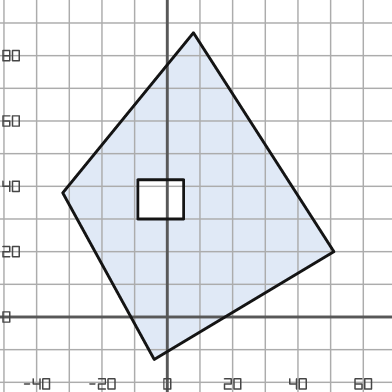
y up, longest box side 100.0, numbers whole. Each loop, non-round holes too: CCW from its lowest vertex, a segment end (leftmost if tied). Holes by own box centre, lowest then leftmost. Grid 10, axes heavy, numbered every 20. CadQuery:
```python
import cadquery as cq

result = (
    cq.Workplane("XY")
    .moveTo(-4.0, -13.0)
    .lineTo(51.0, 20.0)
    .lineTo(8.0, 87.0)
    .lineTo(-32.0, 38.0)
    .close()
    .moveTo(-9.0, 30.0)
    .lineTo(5.0, 30.0)
    .lineTo(5.0, 42.0)
    .lineTo(-9.0, 42.0)
    .close()
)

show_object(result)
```